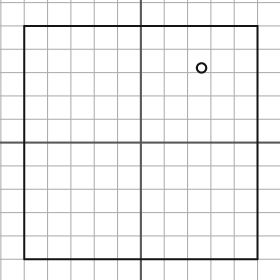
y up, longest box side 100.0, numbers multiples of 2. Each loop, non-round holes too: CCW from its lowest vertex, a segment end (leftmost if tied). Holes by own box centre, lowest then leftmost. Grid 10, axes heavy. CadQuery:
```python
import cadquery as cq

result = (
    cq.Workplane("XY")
    .moveTo(-50.0, -50.0)
    .lineTo(50.0, -50.0)
    .lineTo(50.0, 50.0)
    .lineTo(-50.0, 50.0)
    .close()
    .moveTo(26.0, 32.0)
    .circle(2.0)
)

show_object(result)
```